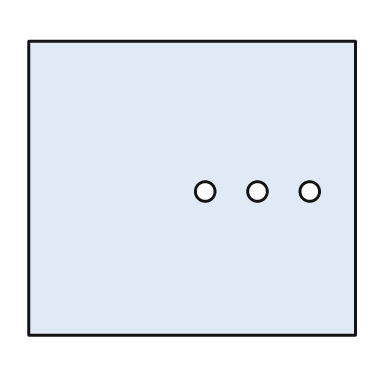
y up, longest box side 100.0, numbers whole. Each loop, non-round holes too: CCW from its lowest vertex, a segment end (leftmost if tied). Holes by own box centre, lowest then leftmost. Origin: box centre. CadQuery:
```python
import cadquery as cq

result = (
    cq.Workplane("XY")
    .moveTo(-50.0, -45.0)
    .lineTo(50.0, -45.0)
    .lineTo(50.0, 45.0)
    .lineTo(-50.0, 45.0)
    .close()
    .moveTo(4.0, -1.0)
    .circle(3.0)
    .moveTo(20.0, -1.0)
    .circle(3.0)
    .moveTo(36.0, -1.0)
    .circle(3.0)
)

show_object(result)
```